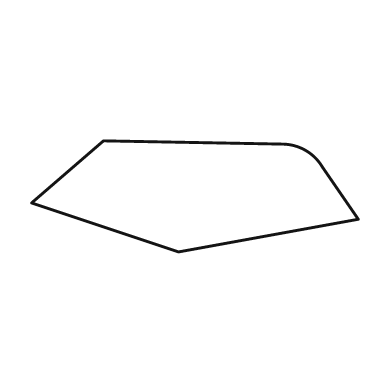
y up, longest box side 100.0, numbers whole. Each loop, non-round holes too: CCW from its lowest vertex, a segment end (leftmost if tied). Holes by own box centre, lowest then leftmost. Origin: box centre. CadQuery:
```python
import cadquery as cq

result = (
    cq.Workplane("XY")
    .moveTo(-5.0, -17.0)
    .lineTo(50.0, -7.0)
    .lineTo(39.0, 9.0)
    .threePointArc((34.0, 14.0), (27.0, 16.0))
    .lineTo(-28.0, 17.0)
    .lineTo(-50.0, -2.0)
    .close()
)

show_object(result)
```